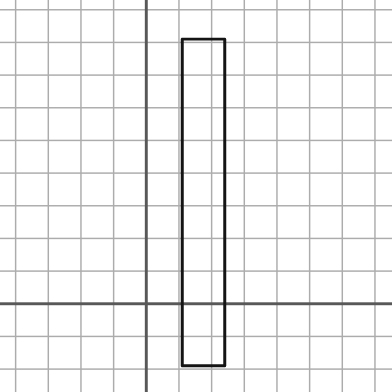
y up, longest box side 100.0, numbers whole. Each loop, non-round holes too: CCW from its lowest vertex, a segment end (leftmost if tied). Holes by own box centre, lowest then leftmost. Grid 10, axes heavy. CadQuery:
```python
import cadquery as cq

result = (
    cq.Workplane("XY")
    .moveTo(11.0, -19.0)
    .lineTo(24.0, -19.0)
    .lineTo(24.0, 81.0)
    .lineTo(11.0, 81.0)
    .close()
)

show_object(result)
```